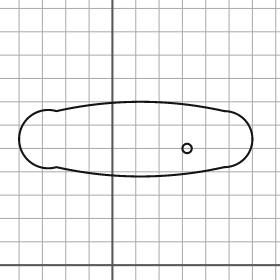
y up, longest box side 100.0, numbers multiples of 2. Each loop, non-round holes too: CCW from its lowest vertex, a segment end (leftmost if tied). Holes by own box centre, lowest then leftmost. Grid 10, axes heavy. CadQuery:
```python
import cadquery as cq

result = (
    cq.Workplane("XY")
    .moveTo(-24.0, 42.0)
    .threePointArc((12.0, 38.0), (48.0, 42.0))
    .threePointArc((60.0, 54.0), (48.0, 66.0))
    .threePointArc((12.0, 70.0), (-24.0, 66.0))
    .threePointArc((-40.0, 54.0), (-24.0, 42.0))
    .close()
    .moveTo(32.0, 50.0)
    .circle(2.0)
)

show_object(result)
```